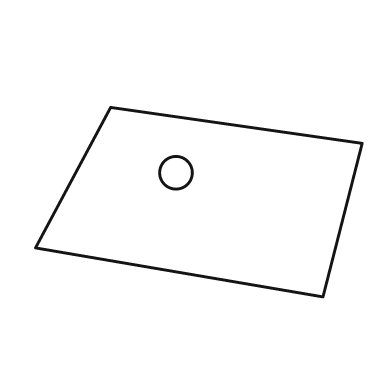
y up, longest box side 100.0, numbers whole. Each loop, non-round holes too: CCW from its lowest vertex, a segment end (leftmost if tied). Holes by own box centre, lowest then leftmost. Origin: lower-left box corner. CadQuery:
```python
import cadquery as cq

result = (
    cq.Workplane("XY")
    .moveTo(88.0, 0.0)
    .lineTo(100.0, 47.0)
    .lineTo(23.0, 58.0)
    .lineTo(0.0, 15.0)
    .close()
    .moveTo(43.0, 38.0)
    .circle(5.0)
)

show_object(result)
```